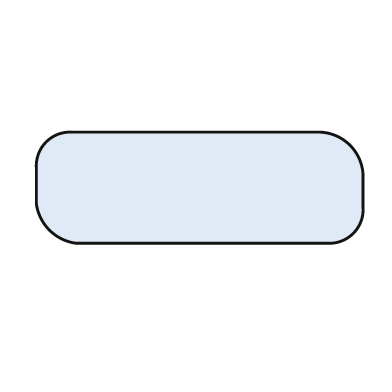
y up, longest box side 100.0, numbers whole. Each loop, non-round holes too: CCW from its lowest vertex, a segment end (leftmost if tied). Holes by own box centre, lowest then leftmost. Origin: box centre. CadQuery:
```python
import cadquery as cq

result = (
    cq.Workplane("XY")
    .moveTo(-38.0, -17.0)
    .lineTo(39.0, -17.0)
    .threePointArc((47.0, -14.0), (50.0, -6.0))
    .lineTo(50.0, 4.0)
    .threePointArc((46.0, 13.0), (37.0, 17.0))
    .lineTo(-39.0, 17.0)
    .threePointArc((-47.0, 14.0), (-50.0, 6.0))
    .lineTo(-50.0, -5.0)
    .threePointArc((-46.0, -13.0), (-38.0, -17.0))
    .close()
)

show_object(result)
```